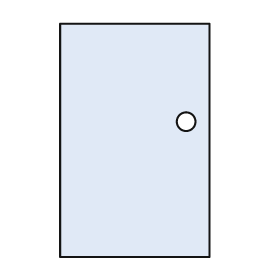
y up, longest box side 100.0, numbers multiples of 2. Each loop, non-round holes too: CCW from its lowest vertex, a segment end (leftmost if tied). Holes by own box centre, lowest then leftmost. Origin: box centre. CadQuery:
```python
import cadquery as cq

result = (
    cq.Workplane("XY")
    .moveTo(-32.0, -50.0)
    .lineTo(32.0, -50.0)
    .lineTo(32.0, 50.0)
    .lineTo(-32.0, 50.0)
    .close()
    .moveTo(22.0, 8.0)
    .circle(4.0)
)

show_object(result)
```